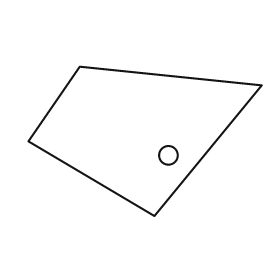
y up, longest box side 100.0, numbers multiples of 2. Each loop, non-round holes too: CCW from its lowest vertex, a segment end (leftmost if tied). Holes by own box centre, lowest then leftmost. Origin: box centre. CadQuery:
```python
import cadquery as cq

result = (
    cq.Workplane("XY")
    .moveTo(4.0, -32.0)
    .lineTo(50.0, 24.0)
    .lineTo(-28.0, 32.0)
    .lineTo(-50.0, 0.0)
    .close()
    .moveTo(10.0, -6.0)
    .circle(4.0)
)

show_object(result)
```